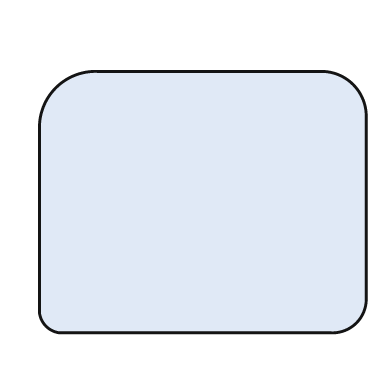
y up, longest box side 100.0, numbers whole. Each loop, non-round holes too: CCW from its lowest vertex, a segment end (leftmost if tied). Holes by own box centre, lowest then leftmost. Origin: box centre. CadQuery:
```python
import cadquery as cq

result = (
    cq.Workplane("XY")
    .moveTo(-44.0, -40.0)
    .lineTo(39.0, -40.0)
    .threePointArc((47.0, -37.0), (50.0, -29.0))
    .lineTo(50.0, 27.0)
    .threePointArc((46.0, 36.0), (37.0, 40.0))
    .lineTo(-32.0, 40.0)
    .threePointArc((-45.0, 35.0), (-50.0, 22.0))
    .lineTo(-50.0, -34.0)
    .threePointArc((-48.0, -38.0), (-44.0, -40.0))
    .close()
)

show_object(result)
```